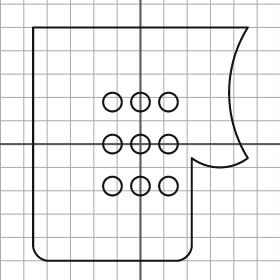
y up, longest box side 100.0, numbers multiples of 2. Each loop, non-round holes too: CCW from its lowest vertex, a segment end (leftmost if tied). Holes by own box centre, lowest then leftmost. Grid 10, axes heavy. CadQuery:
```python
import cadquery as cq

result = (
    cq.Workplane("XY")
    .moveTo(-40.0, -50.0)
    .lineTo(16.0, -50.0)
    .threePointArc((20.0, -48.0), (22.0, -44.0))
    .lineTo(22.0, -6.0)
    .threePointArc((34.0, -10.0), (46.0, -6.0))
    .threePointArc((38.0, 22.0), (46.0, 50.0))
    .lineTo(-46.0, 50.0)
    .lineTo(-46.0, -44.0)
    .threePointArc((-44.0, -48.0), (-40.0, -50.0))
    .close()
    .moveTo(-12.0, -18.0)
    .circle(4.0)
    .moveTo(0.0, -18.0)
    .circle(4.0)
    .moveTo(12.0, -18.0)
    .circle(4.0)
    .moveTo(-12.0, 0.0)
    .circle(4.0)
    .moveTo(0.0, 0.0)
    .circle(4.0)
    .moveTo(12.0, 0.0)
    .circle(4.0)
    .moveTo(-12.0, 18.0)
    .circle(4.0)
    .moveTo(0.0, 18.0)
    .circle(4.0)
    .moveTo(12.0, 18.0)
    .circle(4.0)
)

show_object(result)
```